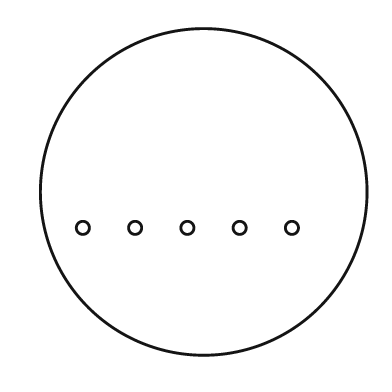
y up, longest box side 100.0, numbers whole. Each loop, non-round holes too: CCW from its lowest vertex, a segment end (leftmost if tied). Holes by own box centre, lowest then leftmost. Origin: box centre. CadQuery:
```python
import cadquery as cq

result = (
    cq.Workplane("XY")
    .moveTo(0.0, 0.0)
    .circle(50.0)
    .moveTo(-37.0, -11.0)
    .circle(2.0)
    .moveTo(-21.0, -11.0)
    .circle(2.0)
    .moveTo(-5.0, -11.0)
    .circle(2.0)
    .moveTo(11.0, -11.0)
    .circle(2.0)
    .moveTo(27.0, -11.0)
    .circle(2.0)
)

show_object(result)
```